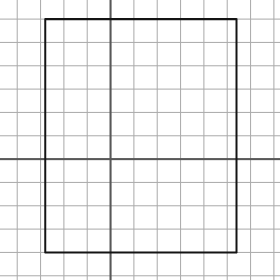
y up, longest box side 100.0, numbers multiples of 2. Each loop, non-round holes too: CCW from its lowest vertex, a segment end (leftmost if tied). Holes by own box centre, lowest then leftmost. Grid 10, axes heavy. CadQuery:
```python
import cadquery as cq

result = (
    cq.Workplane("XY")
    .moveTo(-28.0, -40.0)
    .lineTo(54.0, -40.0)
    .lineTo(54.0, 60.0)
    .lineTo(-28.0, 60.0)
    .close()
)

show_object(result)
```